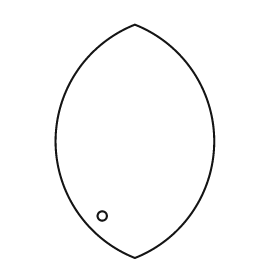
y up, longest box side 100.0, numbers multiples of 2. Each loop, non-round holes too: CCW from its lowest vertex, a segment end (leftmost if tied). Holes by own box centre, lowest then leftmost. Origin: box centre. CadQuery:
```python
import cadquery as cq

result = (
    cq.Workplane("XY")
    .moveTo(0.0, -50.0)
    .threePointArc((34.0, 0.0), (0.0, 50.0))
    .threePointArc((-34.0, 0.0), (0.0, -50.0))
    .close()
    .moveTo(-14.0, -32.0)
    .circle(2.0)
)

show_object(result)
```